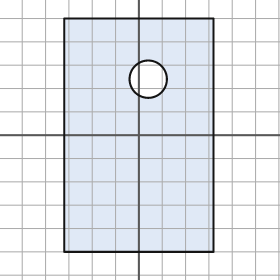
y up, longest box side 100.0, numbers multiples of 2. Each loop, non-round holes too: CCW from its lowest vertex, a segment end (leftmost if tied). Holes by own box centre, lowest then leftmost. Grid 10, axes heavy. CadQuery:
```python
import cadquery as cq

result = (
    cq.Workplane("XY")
    .moveTo(-32.0, -50.0)
    .lineTo(32.0, -50.0)
    .lineTo(32.0, 50.0)
    .lineTo(-32.0, 50.0)
    .close()
    .moveTo(4.0, 24.0)
    .circle(8.0)
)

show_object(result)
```